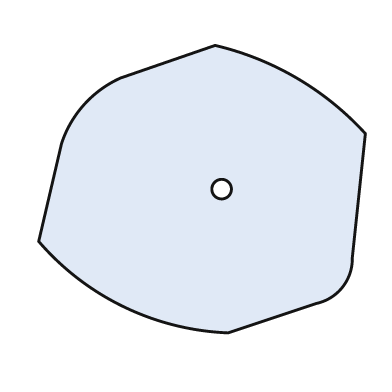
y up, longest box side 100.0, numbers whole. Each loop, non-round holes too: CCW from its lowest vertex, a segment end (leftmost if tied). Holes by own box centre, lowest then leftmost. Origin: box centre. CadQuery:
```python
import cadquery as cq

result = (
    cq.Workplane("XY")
    .moveTo(8.0, -44.0)
    .lineTo(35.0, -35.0)
    .threePointArc((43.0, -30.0), (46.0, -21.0))
    .lineTo(50.0, 17.0)
    .threePointArc((29.0, 34.0), (4.0, 44.0))
    .lineTo(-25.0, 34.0)
    .threePointArc((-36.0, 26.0), (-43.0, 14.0))
    .lineTo(-50.0, -16.0)
    .threePointArc((-24.0, -36.0), (8.0, -44.0))
    .close()
    .moveTo(6.0, 0.0)
    .circle(3.0)
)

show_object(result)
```